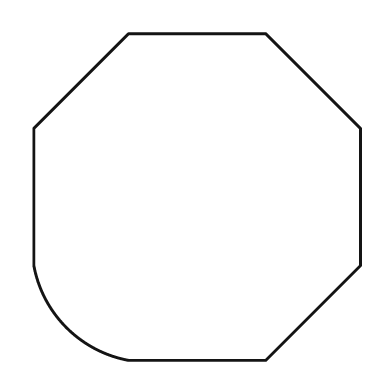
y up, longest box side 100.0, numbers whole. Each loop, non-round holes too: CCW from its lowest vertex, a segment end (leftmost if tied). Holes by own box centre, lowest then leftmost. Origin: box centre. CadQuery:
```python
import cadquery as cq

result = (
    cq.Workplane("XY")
    .moveTo(-21.0, -50.0)
    .lineTo(21.0, -50.0)
    .lineTo(50.0, -21.0)
    .lineTo(50.0, 21.0)
    .lineTo(21.0, 50.0)
    .lineTo(-21.0, 50.0)
    .lineTo(-50.0, 21.0)
    .lineTo(-50.0, -21.0)
    .threePointArc((-40.0, -40.0), (-21.0, -50.0))
    .close()
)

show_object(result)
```